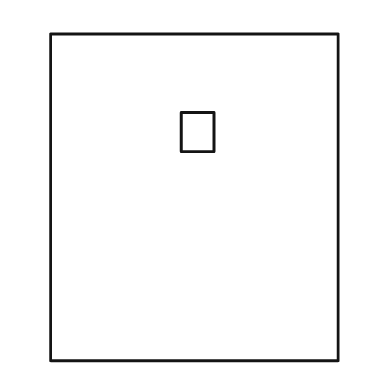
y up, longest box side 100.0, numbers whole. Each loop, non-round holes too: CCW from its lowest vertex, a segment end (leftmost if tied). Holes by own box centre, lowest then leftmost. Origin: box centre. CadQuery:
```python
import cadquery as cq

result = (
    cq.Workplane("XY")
    .moveTo(-44.0, -50.0)
    .lineTo(44.0, -50.0)
    .lineTo(44.0, 50.0)
    .lineTo(-44.0, 50.0)
    .close()
    .moveTo(-4.0, 14.0)
    .lineTo(6.0, 14.0)
    .lineTo(6.0, 26.0)
    .lineTo(-4.0, 26.0)
    .close()
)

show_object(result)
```